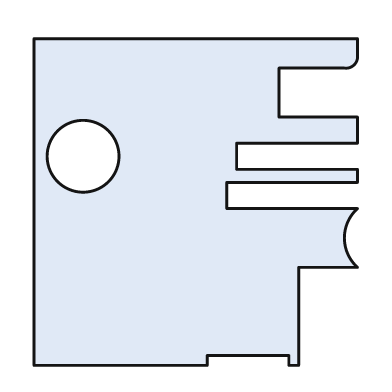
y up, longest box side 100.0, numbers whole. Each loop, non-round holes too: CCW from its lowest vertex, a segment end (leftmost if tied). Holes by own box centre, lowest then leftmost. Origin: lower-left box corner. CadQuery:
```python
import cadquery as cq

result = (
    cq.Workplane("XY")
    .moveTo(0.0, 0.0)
    .lineTo(53.0, 0.0)
    .lineTo(53.0, 3.0)
    .lineTo(78.0, 3.0)
    .lineTo(78.0, 0.0)
    .lineTo(81.0, 0.0)
    .lineTo(81.0, 30.0)
    .lineTo(99.0, 30.0)
    .threePointArc((95.0, 39.0), (99.0, 48.0))
    .lineTo(59.0, 48.0)
    .lineTo(59.0, 56.0)
    .lineTo(99.0, 56.0)
    .lineTo(99.0, 60.0)
    .lineTo(62.0, 60.0)
    .lineTo(62.0, 68.0)
    .lineTo(99.0, 68.0)
    .lineTo(99.0, 76.0)
    .lineTo(75.0, 76.0)
    .lineTo(75.0, 91.0)
    .lineTo(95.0, 91.0)
    .threePointArc((98.0, 92.0), (99.0, 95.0))
    .lineTo(99.0, 100.0)
    .lineTo(0.0, 100.0)
    .close()
    .moveTo(15.0, 64.0)
    .circle(11.0)
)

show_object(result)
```